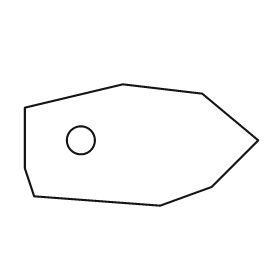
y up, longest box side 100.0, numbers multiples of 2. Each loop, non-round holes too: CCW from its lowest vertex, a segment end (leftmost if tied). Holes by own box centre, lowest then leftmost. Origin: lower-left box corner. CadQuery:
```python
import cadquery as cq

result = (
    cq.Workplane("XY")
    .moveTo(58.0, 0.0)
    .lineTo(80.0, 8.0)
    .lineTo(100.0, 28.0)
    .lineTo(76.0, 48.0)
    .lineTo(42.0, 52.0)
    .lineTo(0.0, 42.0)
    .lineTo(0.0, 16.0)
    .lineTo(4.0, 4.0)
    .close()
    .moveTo(24.0, 28.0)
    .circle(6.0)
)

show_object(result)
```